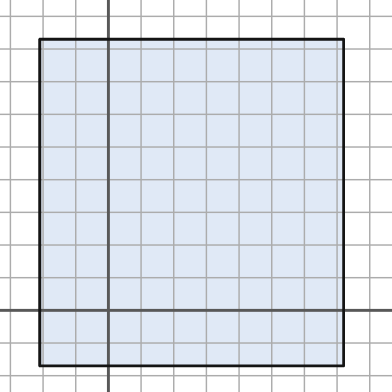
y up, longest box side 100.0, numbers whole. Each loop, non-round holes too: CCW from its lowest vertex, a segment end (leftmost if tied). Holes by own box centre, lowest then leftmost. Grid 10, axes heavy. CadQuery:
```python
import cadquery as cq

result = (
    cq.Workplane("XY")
    .moveTo(-21.0, -17.0)
    .lineTo(72.0, -17.0)
    .lineTo(72.0, 83.0)
    .lineTo(-21.0, 83.0)
    .close()
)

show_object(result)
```